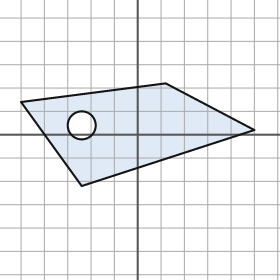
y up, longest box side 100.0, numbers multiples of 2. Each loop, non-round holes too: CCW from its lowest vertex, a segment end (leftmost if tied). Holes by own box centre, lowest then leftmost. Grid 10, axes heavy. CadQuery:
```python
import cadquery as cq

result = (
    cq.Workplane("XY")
    .moveTo(-24.0, -22.0)
    .lineTo(50.0, 2.0)
    .lineTo(12.0, 22.0)
    .lineTo(-50.0, 14.0)
    .close()
    .moveTo(-24.0, 4.0)
    .circle(6.0)
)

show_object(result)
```